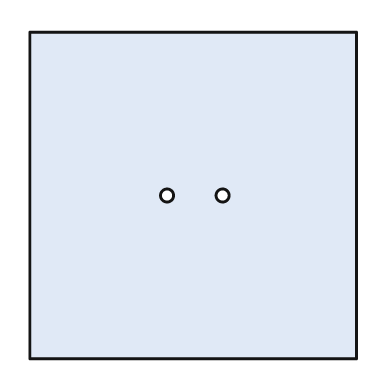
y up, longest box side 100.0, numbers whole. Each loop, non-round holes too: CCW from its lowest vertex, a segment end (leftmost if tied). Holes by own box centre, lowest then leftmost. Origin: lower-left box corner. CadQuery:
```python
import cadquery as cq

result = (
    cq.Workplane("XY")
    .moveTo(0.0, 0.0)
    .lineTo(100.0, 0.0)
    .lineTo(100.0, 100.0)
    .lineTo(0.0, 100.0)
    .close()
    .moveTo(42.0, 50.0)
    .circle(2.0)
    .moveTo(59.0, 50.0)
    .circle(2.0)
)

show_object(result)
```